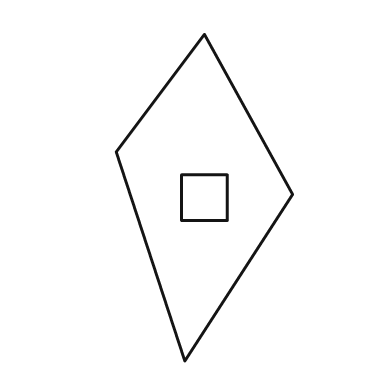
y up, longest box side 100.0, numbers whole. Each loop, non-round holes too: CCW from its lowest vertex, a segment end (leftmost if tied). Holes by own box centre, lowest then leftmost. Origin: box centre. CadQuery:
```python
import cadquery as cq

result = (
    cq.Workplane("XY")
    .moveTo(-6.0, -50.0)
    .lineTo(27.0, 1.0)
    .lineTo(0.0, 50.0)
    .lineTo(-27.0, 14.0)
    .close()
    .moveTo(-7.0, -7.0)
    .lineTo(7.0, -7.0)
    .lineTo(7.0, 7.0)
    .lineTo(-7.0, 7.0)
    .close()
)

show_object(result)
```